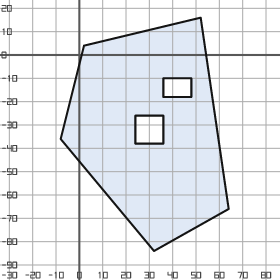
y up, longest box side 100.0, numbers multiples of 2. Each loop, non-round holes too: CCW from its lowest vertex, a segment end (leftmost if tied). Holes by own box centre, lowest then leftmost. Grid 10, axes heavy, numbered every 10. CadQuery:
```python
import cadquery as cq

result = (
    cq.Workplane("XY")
    .moveTo(32.0, -84.0)
    .lineTo(64.0, -66.0)
    .lineTo(52.0, 16.0)
    .lineTo(2.0, 4.0)
    .lineTo(-8.0, -36.0)
    .close()
    .moveTo(24.0, -38.0)
    .lineTo(36.0, -38.0)
    .lineTo(36.0, -26.0)
    .lineTo(24.0, -26.0)
    .close()
    .moveTo(36.0, -18.0)
    .lineTo(48.0, -18.0)
    .lineTo(48.0, -10.0)
    .lineTo(36.0, -10.0)
    .close()
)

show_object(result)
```